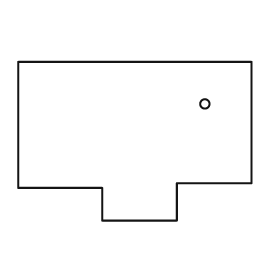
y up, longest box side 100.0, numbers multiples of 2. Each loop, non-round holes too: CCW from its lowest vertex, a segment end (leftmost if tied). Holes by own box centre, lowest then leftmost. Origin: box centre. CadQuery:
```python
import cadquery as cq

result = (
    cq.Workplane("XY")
    .moveTo(-14.0, -34.0)
    .lineTo(18.0, -34.0)
    .lineTo(18.0, -18.0)
    .lineTo(50.0, -18.0)
    .lineTo(50.0, 34.0)
    .lineTo(-50.0, 34.0)
    .lineTo(-50.0, -20.0)
    .lineTo(-14.0, -20.0)
    .close()
    .moveTo(30.0, 16.0)
    .circle(2.0)
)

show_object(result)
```